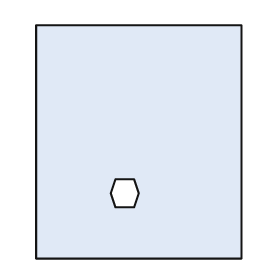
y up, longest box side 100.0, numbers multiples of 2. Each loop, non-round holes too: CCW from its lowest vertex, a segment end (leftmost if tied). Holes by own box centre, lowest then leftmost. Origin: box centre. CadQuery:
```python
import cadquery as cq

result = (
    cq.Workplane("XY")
    .moveTo(-44.0, -50.0)
    .lineTo(44.0, -50.0)
    .lineTo(44.0, 50.0)
    .lineTo(-44.0, 50.0)
    .close()
    .moveTo(-10.0, -28.0)
    .lineTo(-2.0, -28.0)
    .lineTo(0.0, -22.0)
    .lineTo(-2.0, -16.0)
    .lineTo(-10.0, -16.0)
    .lineTo(-12.0, -22.0)
    .close()
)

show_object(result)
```